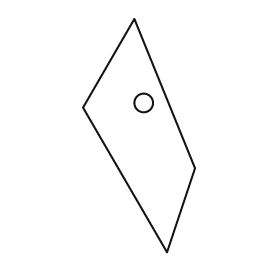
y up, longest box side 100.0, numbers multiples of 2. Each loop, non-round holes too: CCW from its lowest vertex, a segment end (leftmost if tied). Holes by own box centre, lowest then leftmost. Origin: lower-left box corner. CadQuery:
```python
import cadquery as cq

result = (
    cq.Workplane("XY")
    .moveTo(36.0, 0.0)
    .lineTo(48.0, 36.0)
    .lineTo(22.0, 100.0)
    .lineTo(0.0, 62.0)
    .close()
    .moveTo(26.0, 64.0)
    .circle(4.0)
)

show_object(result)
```